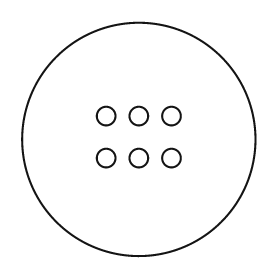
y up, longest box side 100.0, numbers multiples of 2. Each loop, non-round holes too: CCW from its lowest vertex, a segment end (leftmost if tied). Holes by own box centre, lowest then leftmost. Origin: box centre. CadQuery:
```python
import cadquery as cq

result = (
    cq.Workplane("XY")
    .moveTo(0.0, 0.0)
    .circle(50.0)
    .moveTo(-14.0, -8.0)
    .circle(4.0)
    .moveTo(0.0, -8.0)
    .circle(4.0)
    .moveTo(14.0, -8.0)
    .circle(4.0)
    .moveTo(-14.0, 10.0)
    .circle(4.0)
    .moveTo(0.0, 10.0)
    .circle(4.0)
    .moveTo(14.0, 10.0)
    .circle(4.0)
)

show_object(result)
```